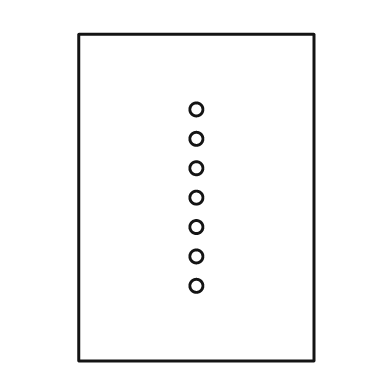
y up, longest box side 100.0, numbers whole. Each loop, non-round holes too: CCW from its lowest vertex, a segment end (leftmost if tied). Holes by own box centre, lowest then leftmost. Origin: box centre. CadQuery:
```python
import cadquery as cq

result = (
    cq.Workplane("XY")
    .moveTo(-36.0, -50.0)
    .lineTo(36.0, -50.0)
    .lineTo(36.0, 50.0)
    .lineTo(-36.0, 50.0)
    .close()
    .moveTo(0.0, -27.0)
    .circle(2.0)
    .moveTo(0.0, -18.0)
    .circle(2.0)
    .moveTo(0.0, -9.0)
    .circle(2.0)
    .moveTo(0.0, 0.0)
    .circle(2.0)
    .moveTo(0.0, 9.0)
    .circle(2.0)
    .moveTo(0.0, 18.0)
    .circle(2.0)
    .moveTo(0.0, 27.0)
    .circle(2.0)
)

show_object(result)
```